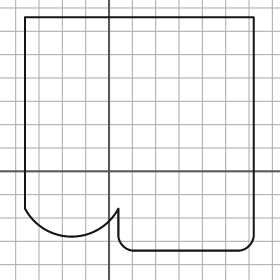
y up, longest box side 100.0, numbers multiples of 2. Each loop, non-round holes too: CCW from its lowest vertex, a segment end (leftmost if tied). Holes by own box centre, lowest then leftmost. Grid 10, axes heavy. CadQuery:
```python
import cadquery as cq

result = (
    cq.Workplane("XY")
    .moveTo(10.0, -34.0)
    .lineTo(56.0, -34.0)
    .threePointArc((60.0, -32.0), (62.0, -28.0))
    .lineTo(62.0, 66.0)
    .lineTo(-36.0, 66.0)
    .lineTo(-36.0, -16.0)
    .threePointArc((-16.0, -28.0), (4.0, -16.0))
    .lineTo(4.0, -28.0)
    .threePointArc((6.0, -32.0), (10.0, -34.0))
    .close()
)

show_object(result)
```